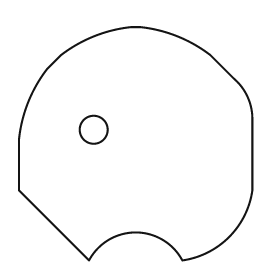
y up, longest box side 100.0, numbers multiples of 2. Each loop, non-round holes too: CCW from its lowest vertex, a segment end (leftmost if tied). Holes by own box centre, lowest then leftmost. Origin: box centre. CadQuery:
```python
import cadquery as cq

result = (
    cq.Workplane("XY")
    .moveTo(-20.0, -50.0)
    .threePointArc((0.0, -38.0), (20.0, -50.0))
    .threePointArc((40.0, -40.0), (50.0, -20.0))
    .lineTo(50.0, 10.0)
    .threePointArc((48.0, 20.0), (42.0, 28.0))
    .lineTo(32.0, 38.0)
    .threePointArc((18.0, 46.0), (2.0, 50.0))
    .lineTo(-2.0, 50.0)
    .threePointArc((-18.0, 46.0), (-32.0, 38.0))
    .lineTo(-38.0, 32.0)
    .threePointArc((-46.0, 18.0), (-50.0, 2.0))
    .lineTo(-50.0, -20.0)
    .close()
    .moveTo(-18.0, 6.0)
    .circle(6.0)
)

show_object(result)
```